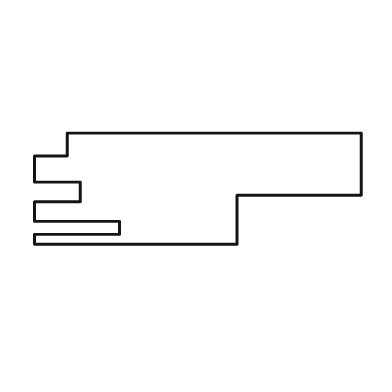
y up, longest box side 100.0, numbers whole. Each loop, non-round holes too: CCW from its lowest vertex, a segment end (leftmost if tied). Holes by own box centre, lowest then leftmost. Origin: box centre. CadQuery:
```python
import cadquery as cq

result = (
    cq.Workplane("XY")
    .moveTo(-50.0, -17.0)
    .lineTo(12.0, -17.0)
    .lineTo(12.0, -2.0)
    .lineTo(50.0, -2.0)
    .lineTo(50.0, 17.0)
    .lineTo(-40.0, 17.0)
    .lineTo(-40.0, 10.0)
    .lineTo(-50.0, 10.0)
    .lineTo(-50.0, 2.0)
    .lineTo(-36.0, 2.0)
    .lineTo(-36.0, -4.0)
    .lineTo(-50.0, -4.0)
    .lineTo(-50.0, -10.0)
    .lineTo(-24.0, -10.0)
    .lineTo(-24.0, -14.0)
    .lineTo(-50.0, -14.0)
    .close()
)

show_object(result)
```